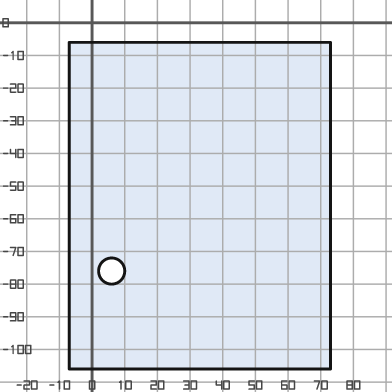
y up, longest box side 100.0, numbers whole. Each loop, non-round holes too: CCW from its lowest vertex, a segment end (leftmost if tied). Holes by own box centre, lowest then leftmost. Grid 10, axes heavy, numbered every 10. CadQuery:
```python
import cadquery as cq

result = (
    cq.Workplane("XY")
    .moveTo(-7.0, -106.0)
    .lineTo(73.0, -106.0)
    .lineTo(73.0, -6.0)
    .lineTo(-7.0, -6.0)
    .close()
    .moveTo(6.0, -76.0)
    .circle(4.0)
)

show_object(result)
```